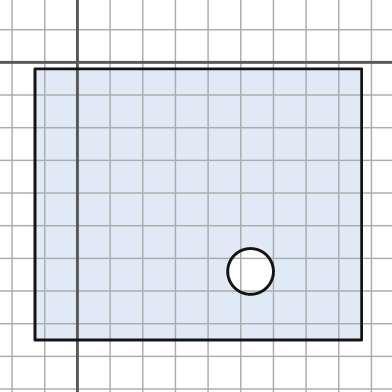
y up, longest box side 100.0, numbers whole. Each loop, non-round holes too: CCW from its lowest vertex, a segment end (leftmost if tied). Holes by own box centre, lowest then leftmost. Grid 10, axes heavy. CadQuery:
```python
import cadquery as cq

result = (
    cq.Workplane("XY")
    .moveTo(-13.0, -85.0)
    .lineTo(87.0, -85.0)
    .lineTo(87.0, -2.0)
    .lineTo(-13.0, -2.0)
    .close()
    .moveTo(53.0, -64.0)
    .circle(7.0)
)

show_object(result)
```